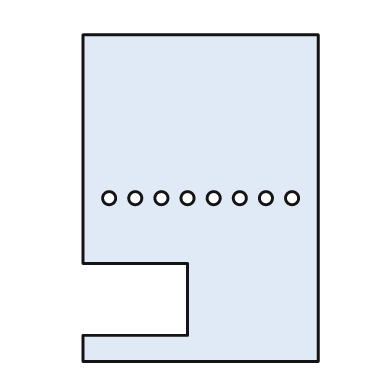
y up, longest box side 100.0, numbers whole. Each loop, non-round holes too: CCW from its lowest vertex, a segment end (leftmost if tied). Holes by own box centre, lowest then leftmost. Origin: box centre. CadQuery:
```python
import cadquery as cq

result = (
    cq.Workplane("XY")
    .moveTo(-36.0, -50.0)
    .lineTo(36.0, -50.0)
    .lineTo(36.0, 50.0)
    .lineTo(-36.0, 50.0)
    .lineTo(-36.0, -20.0)
    .lineTo(-4.0, -20.0)
    .lineTo(-4.0, -42.0)
    .lineTo(-36.0, -42.0)
    .close()
    .moveTo(-28.0, 0.0)
    .circle(2.0)
    .moveTo(-20.0, 0.0)
    .circle(2.0)
    .moveTo(-12.0, 0.0)
    .circle(2.0)
    .moveTo(-4.0, 0.0)
    .circle(2.0)
    .moveTo(4.0, 0.0)
    .circle(2.0)
    .moveTo(12.0, 0.0)
    .circle(2.0)
    .moveTo(20.0, 0.0)
    .circle(2.0)
    .moveTo(28.0, 0.0)
    .circle(2.0)
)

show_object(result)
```